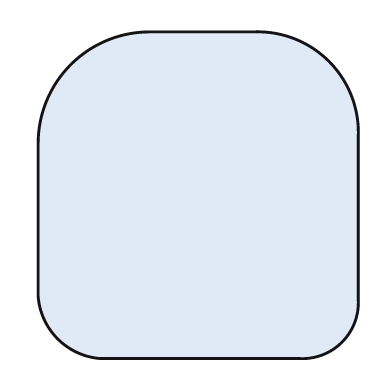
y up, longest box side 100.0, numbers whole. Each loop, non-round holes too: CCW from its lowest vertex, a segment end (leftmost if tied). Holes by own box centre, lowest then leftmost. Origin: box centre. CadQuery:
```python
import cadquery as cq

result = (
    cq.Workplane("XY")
    .moveTo(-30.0, -50.0)
    .lineTo(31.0, -50.0)
    .threePointArc((44.0, -45.0), (49.0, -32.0))
    .lineTo(49.0, 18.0)
    .threePointArc((40.0, 41.0), (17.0, 50.0))
    .lineTo(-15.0, 50.0)
    .threePointArc((-39.0, 40.0), (-49.0, 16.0))
    .lineTo(-49.0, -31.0)
    .threePointArc((-43.0, -44.0), (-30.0, -50.0))
    .close()
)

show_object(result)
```